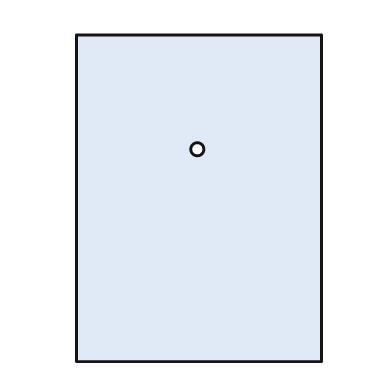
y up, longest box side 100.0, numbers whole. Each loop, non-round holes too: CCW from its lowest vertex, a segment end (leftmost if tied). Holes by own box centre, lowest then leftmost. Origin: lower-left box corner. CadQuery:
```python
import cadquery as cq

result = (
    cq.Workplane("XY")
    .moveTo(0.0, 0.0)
    .lineTo(75.0, 0.0)
    .lineTo(75.0, 100.0)
    .lineTo(0.0, 100.0)
    .close()
    .moveTo(37.0, 65.0)
    .circle(2.0)
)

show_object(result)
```